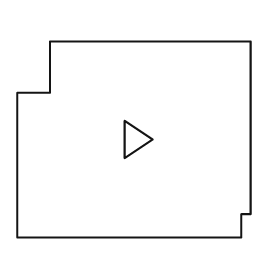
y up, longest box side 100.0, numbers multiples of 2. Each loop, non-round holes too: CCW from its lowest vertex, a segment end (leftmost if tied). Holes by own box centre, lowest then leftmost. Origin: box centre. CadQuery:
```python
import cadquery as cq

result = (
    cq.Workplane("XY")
    .moveTo(-50.0, -42.0)
    .lineTo(46.0, -42.0)
    .lineTo(46.0, -32.0)
    .lineTo(50.0, -32.0)
    .lineTo(50.0, 42.0)
    .lineTo(-36.0, 42.0)
    .lineTo(-36.0, 20.0)
    .lineTo(-50.0, 20.0)
    .close()
    .moveTo(-4.0, -8.0)
    .lineTo(8.0, 0.0)
    .lineTo(-4.0, 8.0)
    .close()
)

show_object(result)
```